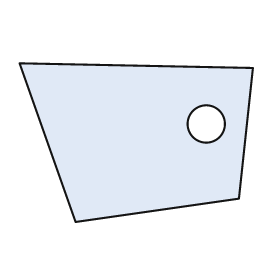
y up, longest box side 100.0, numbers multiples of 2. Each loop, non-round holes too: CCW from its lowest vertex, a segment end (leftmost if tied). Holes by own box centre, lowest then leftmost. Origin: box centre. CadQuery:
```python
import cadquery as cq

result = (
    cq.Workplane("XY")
    .moveTo(-26.0, -34.0)
    .lineTo(44.0, -24.0)
    .lineTo(50.0, 32.0)
    .lineTo(-50.0, 34.0)
    .close()
    .moveTo(30.0, 8.0)
    .circle(8.0)
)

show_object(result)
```